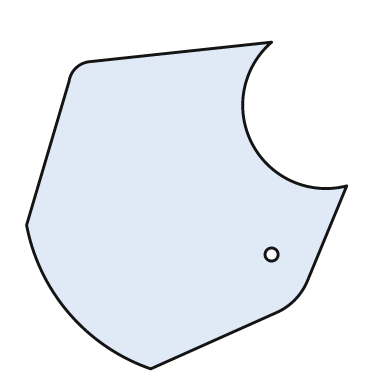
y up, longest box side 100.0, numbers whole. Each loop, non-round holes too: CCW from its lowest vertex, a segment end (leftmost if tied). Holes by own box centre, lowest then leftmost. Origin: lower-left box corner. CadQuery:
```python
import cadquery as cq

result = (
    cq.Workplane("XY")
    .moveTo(38.0, 0.0)
    .lineTo(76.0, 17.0)
    .threePointArc((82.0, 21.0), (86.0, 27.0))
    .lineTo(98.0, 56.0)
    .threePointArc((69.0, 69.0), (75.0, 100.0))
    .lineTo(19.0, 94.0)
    .threePointArc((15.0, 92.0), (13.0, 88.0))
    .lineTo(0.0, 44.0)
    .threePointArc((13.0, 17.0), (38.0, 0.0))
    .close()
    .moveTo(75.0, 35.0)
    .circle(2.0)
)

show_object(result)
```